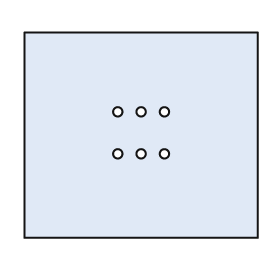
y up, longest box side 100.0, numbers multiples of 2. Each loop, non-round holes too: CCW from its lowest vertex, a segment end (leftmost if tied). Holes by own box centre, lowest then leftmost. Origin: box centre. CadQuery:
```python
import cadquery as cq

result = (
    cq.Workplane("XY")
    .moveTo(-50.0, -44.0)
    .lineTo(50.0, -44.0)
    .lineTo(50.0, 44.0)
    .lineTo(-50.0, 44.0)
    .close()
    .moveTo(-10.0, -8.0)
    .circle(2.0)
    .moveTo(0.0, -8.0)
    .circle(2.0)
    .moveTo(10.0, -8.0)
    .circle(2.0)
    .moveTo(-10.0, 10.0)
    .circle(2.0)
    .moveTo(0.0, 10.0)
    .circle(2.0)
    .moveTo(10.0, 10.0)
    .circle(2.0)
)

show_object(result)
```